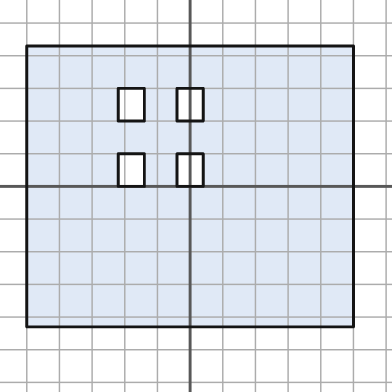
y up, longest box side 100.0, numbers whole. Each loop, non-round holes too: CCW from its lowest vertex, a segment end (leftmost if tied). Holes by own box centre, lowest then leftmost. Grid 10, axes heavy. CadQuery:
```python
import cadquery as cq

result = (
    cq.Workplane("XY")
    .moveTo(-50.0, -43.0)
    .lineTo(50.0, -43.0)
    .lineTo(50.0, 43.0)
    .lineTo(-50.0, 43.0)
    .close()
    .moveTo(-22.0, 0.0)
    .lineTo(-14.0, 0.0)
    .lineTo(-14.0, 10.0)
    .lineTo(-22.0, 10.0)
    .close()
    .moveTo(-4.0, 0.0)
    .lineTo(4.0, 0.0)
    .lineTo(4.0, 10.0)
    .lineTo(-4.0, 10.0)
    .close()
    .moveTo(-22.0, 20.0)
    .lineTo(-14.0, 20.0)
    .lineTo(-14.0, 30.0)
    .lineTo(-22.0, 30.0)
    .close()
    .moveTo(-4.0, 20.0)
    .lineTo(4.0, 20.0)
    .lineTo(4.0, 30.0)
    .lineTo(-4.0, 30.0)
    .close()
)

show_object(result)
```